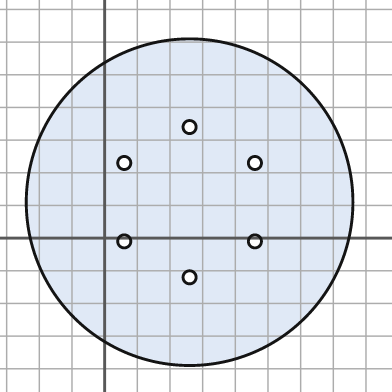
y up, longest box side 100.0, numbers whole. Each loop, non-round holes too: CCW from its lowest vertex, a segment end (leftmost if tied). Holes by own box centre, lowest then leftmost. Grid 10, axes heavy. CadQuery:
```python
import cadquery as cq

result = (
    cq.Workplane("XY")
    .moveTo(26.0, 11.0)
    .circle(50.0)
    .moveTo(26.0, -12.0)
    .circle(2.0)
    .moveTo(6.0, -1.0)
    .circle(2.0)
    .moveTo(46.0, -1.0)
    .circle(2.0)
    .moveTo(6.0, 23.0)
    .circle(2.0)
    .moveTo(46.0, 23.0)
    .circle(2.0)
    .moveTo(26.0, 34.0)
    .circle(2.0)
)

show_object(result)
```